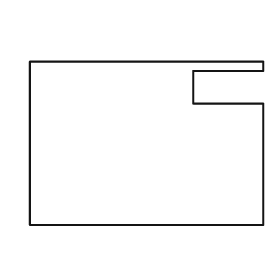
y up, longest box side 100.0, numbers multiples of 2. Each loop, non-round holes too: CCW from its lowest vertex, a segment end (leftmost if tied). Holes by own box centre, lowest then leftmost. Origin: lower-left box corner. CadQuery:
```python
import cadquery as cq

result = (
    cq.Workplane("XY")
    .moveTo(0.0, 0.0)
    .lineTo(100.0, 0.0)
    .lineTo(100.0, 52.0)
    .lineTo(70.0, 52.0)
    .lineTo(70.0, 66.0)
    .lineTo(100.0, 66.0)
    .lineTo(100.0, 70.0)
    .lineTo(0.0, 70.0)
    .close()
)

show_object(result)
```